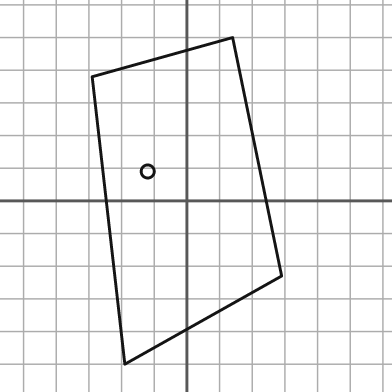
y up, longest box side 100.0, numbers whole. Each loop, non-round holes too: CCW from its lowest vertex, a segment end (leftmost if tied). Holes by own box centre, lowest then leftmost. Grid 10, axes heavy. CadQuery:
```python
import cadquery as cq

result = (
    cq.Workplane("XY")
    .moveTo(-19.0, -50.0)
    .lineTo(29.0, -23.0)
    .lineTo(14.0, 50.0)
    .lineTo(-29.0, 38.0)
    .close()
    .moveTo(-12.0, 9.0)
    .circle(2.0)
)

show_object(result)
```